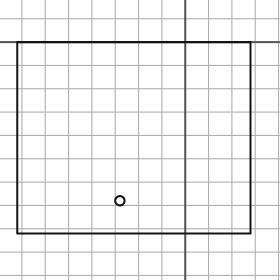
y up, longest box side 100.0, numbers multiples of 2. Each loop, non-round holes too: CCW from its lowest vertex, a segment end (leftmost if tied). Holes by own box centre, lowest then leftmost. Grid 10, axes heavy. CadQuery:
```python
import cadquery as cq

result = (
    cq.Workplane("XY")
    .moveTo(-72.0, -82.0)
    .lineTo(28.0, -82.0)
    .lineTo(28.0, 0.0)
    .lineTo(-72.0, 0.0)
    .close()
    .moveTo(-28.0, -68.0)
    .circle(2.0)
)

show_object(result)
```